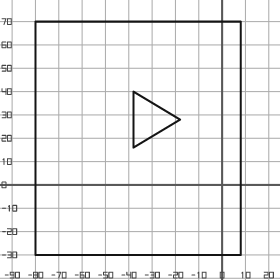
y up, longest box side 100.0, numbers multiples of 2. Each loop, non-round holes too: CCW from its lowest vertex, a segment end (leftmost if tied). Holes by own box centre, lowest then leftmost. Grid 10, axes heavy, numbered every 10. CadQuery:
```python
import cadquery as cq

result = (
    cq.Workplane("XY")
    .moveTo(-80.0, -30.0)
    .lineTo(8.0, -30.0)
    .lineTo(8.0, 70.0)
    .lineTo(-80.0, 70.0)
    .close()
    .moveTo(-38.0, 16.0)
    .lineTo(-18.0, 28.0)
    .lineTo(-38.0, 40.0)
    .close()
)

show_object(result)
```